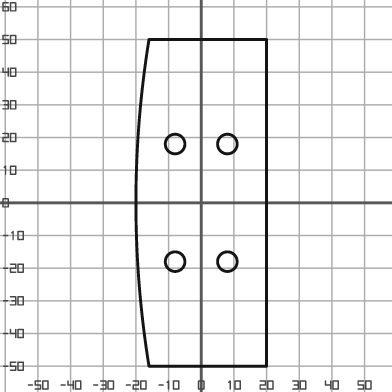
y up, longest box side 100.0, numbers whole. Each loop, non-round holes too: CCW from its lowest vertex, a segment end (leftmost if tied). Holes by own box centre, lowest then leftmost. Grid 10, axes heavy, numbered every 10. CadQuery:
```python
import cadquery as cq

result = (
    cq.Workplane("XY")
    .moveTo(-16.0, -50.0)
    .lineTo(20.0, -50.0)
    .lineTo(20.0, 50.0)
    .lineTo(-16.0, 50.0)
    .threePointArc((-20.0, 0.0), (-16.0, -50.0))
    .close()
    .moveTo(-8.0, -18.0)
    .circle(3.0)
    .moveTo(8.0, -18.0)
    .circle(3.0)
    .moveTo(-8.0, 18.0)
    .circle(3.0)
    .moveTo(8.0, 18.0)
    .circle(3.0)
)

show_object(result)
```